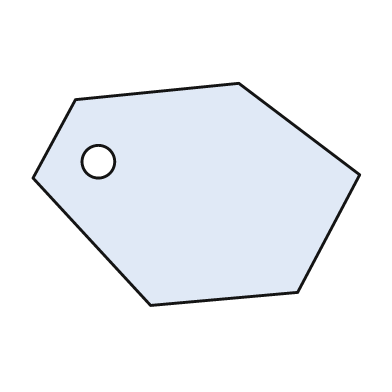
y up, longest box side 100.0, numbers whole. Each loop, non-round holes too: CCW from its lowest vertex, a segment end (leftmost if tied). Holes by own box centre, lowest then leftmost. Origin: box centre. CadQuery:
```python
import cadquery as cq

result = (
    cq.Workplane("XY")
    .moveTo(-14.0, -34.0)
    .lineTo(31.0, -30.0)
    .lineTo(50.0, 6.0)
    .lineTo(13.0, 34.0)
    .lineTo(-37.0, 29.0)
    .lineTo(-50.0, 5.0)
    .close()
    .moveTo(-30.0, 10.0)
    .circle(5.0)
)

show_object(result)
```